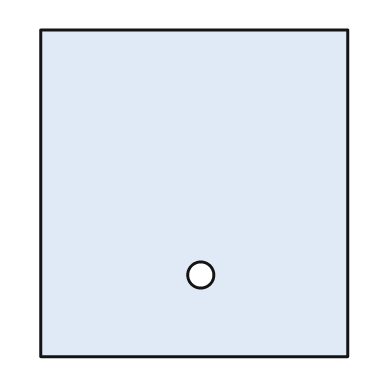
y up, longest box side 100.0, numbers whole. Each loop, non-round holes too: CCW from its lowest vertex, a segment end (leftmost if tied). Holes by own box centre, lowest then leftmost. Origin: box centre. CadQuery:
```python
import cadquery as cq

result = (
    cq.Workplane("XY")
    .moveTo(-47.0, -50.0)
    .lineTo(47.0, -50.0)
    .lineTo(47.0, 50.0)
    .lineTo(-47.0, 50.0)
    .close()
    .moveTo(2.0, -25.0)
    .circle(4.0)
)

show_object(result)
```